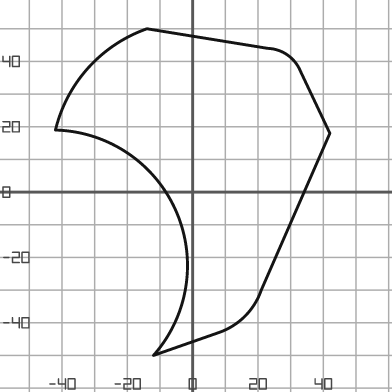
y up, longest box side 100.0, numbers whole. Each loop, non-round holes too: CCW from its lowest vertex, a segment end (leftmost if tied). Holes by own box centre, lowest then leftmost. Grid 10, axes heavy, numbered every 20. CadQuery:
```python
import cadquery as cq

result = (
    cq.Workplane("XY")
    .moveTo(-12.0, -50.0)
    .lineTo(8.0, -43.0)
    .threePointArc((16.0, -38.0), (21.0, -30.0))
    .lineTo(42.0, 18.0)
    .lineTo(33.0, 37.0)
    .threePointArc((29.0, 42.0), (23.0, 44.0))
    .lineTo(-14.0, 50.0)
    .threePointArc((-32.0, 38.0), (-42.0, 19.0))
    .threePointArc((-5.0, -6.0), (-12.0, -50.0))
    .close()
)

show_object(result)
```